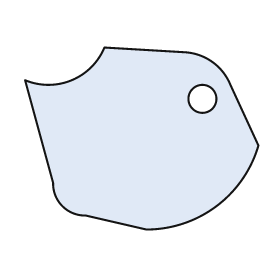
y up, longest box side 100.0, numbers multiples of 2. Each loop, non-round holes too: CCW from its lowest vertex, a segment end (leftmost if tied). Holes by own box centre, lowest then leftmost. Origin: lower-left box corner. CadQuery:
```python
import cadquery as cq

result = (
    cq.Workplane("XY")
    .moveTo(52.0, 0.0)
    .threePointArc((82.0, 10.0), (100.0, 36.0))
    .lineTo(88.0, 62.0)
    .threePointArc((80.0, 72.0), (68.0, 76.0))
    .lineTo(34.0, 78.0)
    .threePointArc((20.0, 64.0), (0.0, 64.0))
    .lineTo(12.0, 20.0)
    .threePointArc((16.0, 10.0), (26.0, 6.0))
    .close()
    .moveTo(76.0, 56.0)
    .circle(6.0)
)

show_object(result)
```